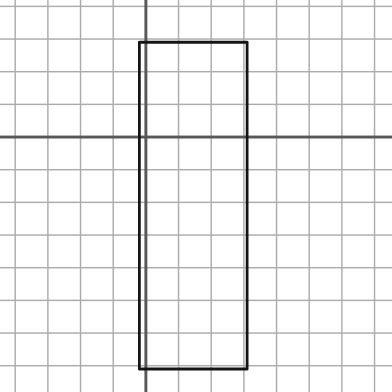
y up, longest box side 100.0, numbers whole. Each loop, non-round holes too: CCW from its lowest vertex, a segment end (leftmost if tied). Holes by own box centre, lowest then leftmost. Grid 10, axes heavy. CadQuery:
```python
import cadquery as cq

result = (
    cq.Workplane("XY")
    .moveTo(-2.0, -71.0)
    .lineTo(31.0, -71.0)
    .lineTo(31.0, 29.0)
    .lineTo(-2.0, 29.0)
    .close()
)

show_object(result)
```